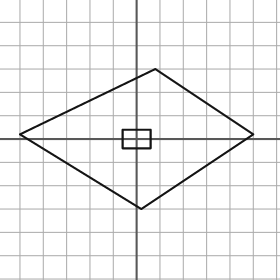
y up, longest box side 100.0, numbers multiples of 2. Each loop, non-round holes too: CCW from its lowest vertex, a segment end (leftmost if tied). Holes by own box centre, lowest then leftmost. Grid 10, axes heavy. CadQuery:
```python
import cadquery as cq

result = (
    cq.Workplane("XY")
    .moveTo(2.0, -30.0)
    .lineTo(50.0, 2.0)
    .lineTo(8.0, 30.0)
    .lineTo(-50.0, 2.0)
    .close()
    .moveTo(-6.0, -4.0)
    .lineTo(6.0, -4.0)
    .lineTo(6.0, 4.0)
    .lineTo(-6.0, 4.0)
    .close()
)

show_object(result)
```